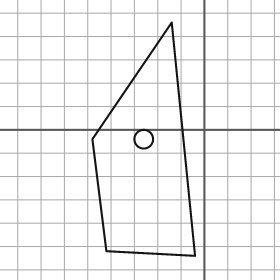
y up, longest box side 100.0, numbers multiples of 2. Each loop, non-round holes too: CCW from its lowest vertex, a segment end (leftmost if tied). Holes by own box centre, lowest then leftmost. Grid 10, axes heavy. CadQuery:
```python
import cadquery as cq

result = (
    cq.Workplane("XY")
    .moveTo(-4.0, -54.0)
    .lineTo(-14.0, 46.0)
    .lineTo(-48.0, -4.0)
    .lineTo(-42.0, -52.0)
    .close()
    .moveTo(-26.0, -4.0)
    .circle(4.0)
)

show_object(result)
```